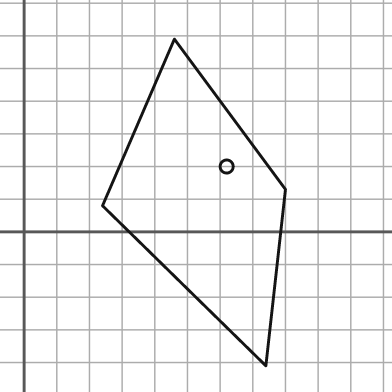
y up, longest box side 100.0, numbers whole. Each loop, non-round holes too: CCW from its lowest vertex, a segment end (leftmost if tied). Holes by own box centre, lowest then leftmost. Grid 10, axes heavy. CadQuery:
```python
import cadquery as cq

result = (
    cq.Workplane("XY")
    .moveTo(74.0, -41.0)
    .lineTo(80.0, 13.0)
    .lineTo(46.0, 59.0)
    .lineTo(24.0, 8.0)
    .close()
    .moveTo(62.0, 20.0)
    .circle(2.0)
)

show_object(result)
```